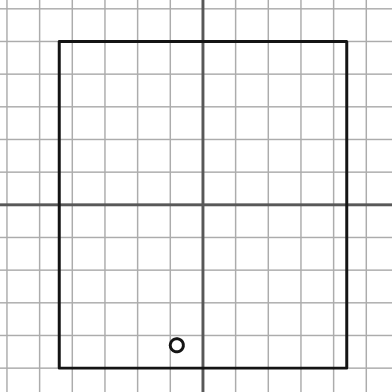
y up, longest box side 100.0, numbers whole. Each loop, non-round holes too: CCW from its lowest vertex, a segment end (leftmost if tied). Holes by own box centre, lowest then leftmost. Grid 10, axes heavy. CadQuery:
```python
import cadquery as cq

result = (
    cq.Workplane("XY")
    .moveTo(-44.0, -50.0)
    .lineTo(44.0, -50.0)
    .lineTo(44.0, 50.0)
    .lineTo(-44.0, 50.0)
    .close()
    .moveTo(-8.0, -43.0)
    .circle(2.0)
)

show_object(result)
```